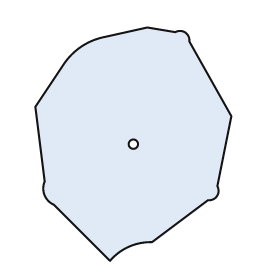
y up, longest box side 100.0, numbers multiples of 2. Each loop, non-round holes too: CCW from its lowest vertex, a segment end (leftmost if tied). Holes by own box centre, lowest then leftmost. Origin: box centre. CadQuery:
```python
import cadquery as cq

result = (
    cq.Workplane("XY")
    .moveTo(-10.0, -50.0)
    .threePointArc((-2.0, -44.0), (8.0, -42.0))
    .lineTo(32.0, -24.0)
    .threePointArc((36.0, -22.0), (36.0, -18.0))
    .lineTo(42.0, 12.0)
    .lineTo(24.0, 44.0)
    .threePointArc((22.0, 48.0), (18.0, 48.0))
    .lineTo(6.0, 50.0)
    .lineTo(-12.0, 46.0)
    .threePointArc((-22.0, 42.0), (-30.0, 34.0))
    .lineTo(-42.0, 16.0)
    .lineTo(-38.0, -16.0)
    .threePointArc((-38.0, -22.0), (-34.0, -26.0))
    .close()
    .moveTo(0.0, 0.0)
    .circle(2.0)
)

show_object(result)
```